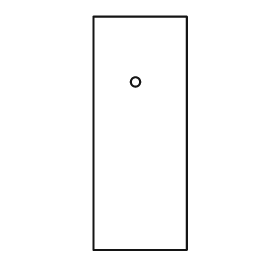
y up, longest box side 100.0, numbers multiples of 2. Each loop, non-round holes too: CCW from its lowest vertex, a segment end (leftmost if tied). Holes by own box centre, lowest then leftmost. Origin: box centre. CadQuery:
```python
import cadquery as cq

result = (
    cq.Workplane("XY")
    .moveTo(-20.0, -50.0)
    .lineTo(20.0, -50.0)
    .lineTo(20.0, 50.0)
    .lineTo(-20.0, 50.0)
    .close()
    .moveTo(-2.0, 22.0)
    .circle(2.0)
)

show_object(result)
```